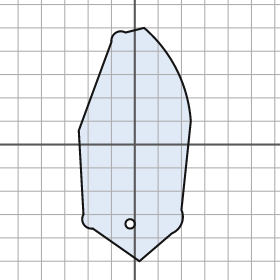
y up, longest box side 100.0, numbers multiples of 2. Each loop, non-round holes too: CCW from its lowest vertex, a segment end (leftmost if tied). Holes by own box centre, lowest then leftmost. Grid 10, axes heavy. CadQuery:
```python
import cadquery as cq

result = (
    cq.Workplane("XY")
    .moveTo(2.0, -50.0)
    .lineTo(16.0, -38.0)
    .threePointArc((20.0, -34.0), (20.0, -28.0))
    .lineTo(24.0, 10.0)
    .threePointArc((18.0, 32.0), (4.0, 50.0))
    .lineTo(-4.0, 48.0)
    .threePointArc((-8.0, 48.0), (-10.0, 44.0))
    .lineTo(-24.0, 6.0)
    .lineTo(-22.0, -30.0)
    .threePointArc((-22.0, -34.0), (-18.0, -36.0))
    .close()
    .moveTo(-2.0, -34.0)
    .circle(2.0)
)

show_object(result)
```